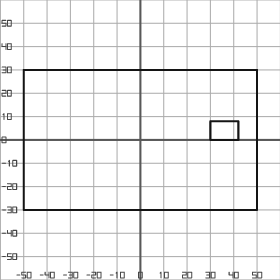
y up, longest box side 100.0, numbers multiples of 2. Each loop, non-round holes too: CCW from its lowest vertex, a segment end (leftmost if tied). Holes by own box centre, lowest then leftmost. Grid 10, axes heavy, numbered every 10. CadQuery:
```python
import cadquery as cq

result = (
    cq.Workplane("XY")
    .moveTo(-50.0, -30.0)
    .lineTo(50.0, -30.0)
    .lineTo(50.0, 30.0)
    .lineTo(-50.0, 30.0)
    .close()
    .moveTo(30.0, 0.0)
    .lineTo(42.0, 0.0)
    .lineTo(42.0, 8.0)
    .lineTo(30.0, 8.0)
    .close()
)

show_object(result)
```